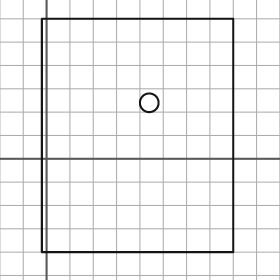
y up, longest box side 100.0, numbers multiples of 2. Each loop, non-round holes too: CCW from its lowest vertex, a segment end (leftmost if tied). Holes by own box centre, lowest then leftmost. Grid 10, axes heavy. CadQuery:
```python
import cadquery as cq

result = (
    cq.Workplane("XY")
    .moveTo(-2.0, -40.0)
    .lineTo(80.0, -40.0)
    .lineTo(80.0, 60.0)
    .lineTo(-2.0, 60.0)
    .close()
    .moveTo(44.0, 24.0)
    .circle(4.0)
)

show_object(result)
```